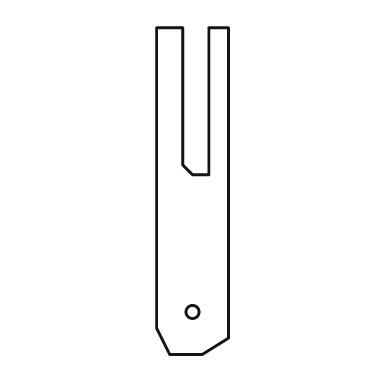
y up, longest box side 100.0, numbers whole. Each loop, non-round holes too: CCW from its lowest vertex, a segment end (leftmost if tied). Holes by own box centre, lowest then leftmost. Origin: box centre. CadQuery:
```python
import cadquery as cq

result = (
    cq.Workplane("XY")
    .moveTo(-7.0, -50.0)
    .lineTo(3.0, -50.0)
    .lineTo(11.0, -45.0)
    .lineTo(11.0, 50.0)
    .lineTo(5.0, 50.0)
    .lineTo(5.0, 5.0)
    .lineTo(0.0, 5.0)
    .lineTo(-3.0, 8.0)
    .lineTo(-3.0, 50.0)
    .lineTo(-11.0, 50.0)
    .lineTo(-11.0, -42.0)
    .close()
    .moveTo(0.0, -37.0)
    .circle(2.0)
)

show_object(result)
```